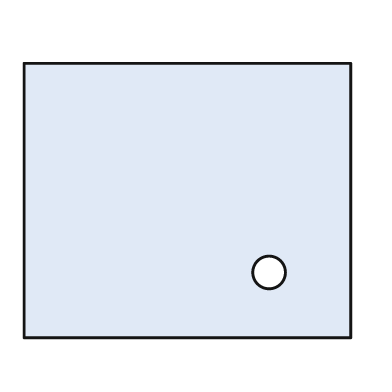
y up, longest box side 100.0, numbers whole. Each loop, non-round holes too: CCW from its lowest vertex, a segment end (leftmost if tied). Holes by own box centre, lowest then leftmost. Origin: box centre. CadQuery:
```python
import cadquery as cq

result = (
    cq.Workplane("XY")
    .moveTo(-50.0, -42.0)
    .lineTo(50.0, -42.0)
    .lineTo(50.0, 42.0)
    .lineTo(-50.0, 42.0)
    .close()
    .moveTo(25.0, -22.0)
    .circle(5.0)
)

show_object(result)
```